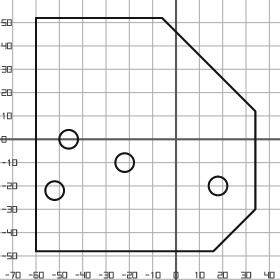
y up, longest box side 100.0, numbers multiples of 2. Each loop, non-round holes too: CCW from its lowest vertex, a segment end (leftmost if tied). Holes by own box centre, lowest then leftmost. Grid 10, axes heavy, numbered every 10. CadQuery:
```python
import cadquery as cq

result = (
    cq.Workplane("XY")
    .moveTo(-60.0, -48.0)
    .lineTo(16.0, -48.0)
    .lineTo(34.0, -30.0)
    .lineTo(34.0, 12.0)
    .lineTo(-6.0, 52.0)
    .lineTo(-60.0, 52.0)
    .close()
    .moveTo(-52.0, -22.0)
    .circle(4.0)
    .moveTo(18.0, -20.0)
    .circle(4.0)
    .moveTo(-22.0, -10.0)
    .circle(4.0)
    .moveTo(-46.0, 0.0)
    .circle(4.0)
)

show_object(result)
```